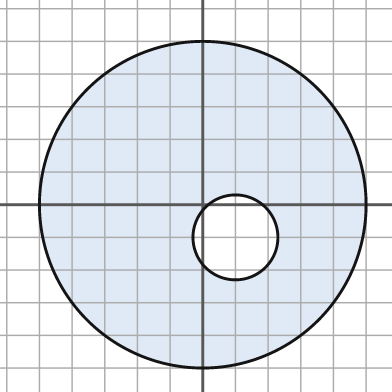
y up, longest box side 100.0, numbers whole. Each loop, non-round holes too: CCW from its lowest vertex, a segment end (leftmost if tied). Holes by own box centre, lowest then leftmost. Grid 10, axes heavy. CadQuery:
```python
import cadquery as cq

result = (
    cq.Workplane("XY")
    .moveTo(0.0, 0.0)
    .circle(50.0)
    .moveTo(10.0, -10.0)
    .circle(13.0)
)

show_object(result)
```